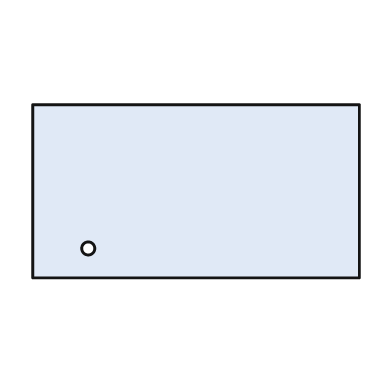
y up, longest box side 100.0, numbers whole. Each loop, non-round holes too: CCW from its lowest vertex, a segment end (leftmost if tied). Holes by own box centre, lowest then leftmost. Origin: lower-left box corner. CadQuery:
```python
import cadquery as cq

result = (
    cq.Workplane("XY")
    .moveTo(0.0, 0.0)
    .lineTo(100.0, 0.0)
    .lineTo(100.0, 53.0)
    .lineTo(0.0, 53.0)
    .close()
    .moveTo(17.0, 9.0)
    .circle(2.0)
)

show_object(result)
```